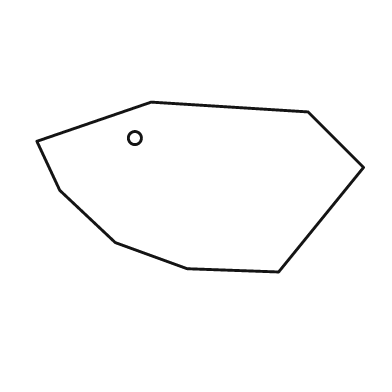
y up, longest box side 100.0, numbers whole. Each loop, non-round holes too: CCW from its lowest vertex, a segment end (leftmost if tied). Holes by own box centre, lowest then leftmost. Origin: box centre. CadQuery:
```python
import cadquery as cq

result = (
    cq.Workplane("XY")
    .moveTo(24.0, -26.0)
    .lineTo(50.0, 6.0)
    .lineTo(33.0, 23.0)
    .lineTo(-15.0, 26.0)
    .lineTo(-50.0, 14.0)
    .lineTo(-43.0, -1.0)
    .lineTo(-26.0, -17.0)
    .lineTo(-4.0, -25.0)
    .close()
    .moveTo(-20.0, 15.0)
    .circle(2.0)
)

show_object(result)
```